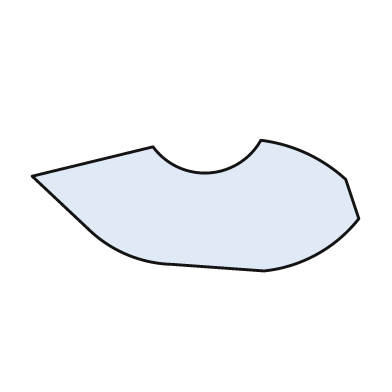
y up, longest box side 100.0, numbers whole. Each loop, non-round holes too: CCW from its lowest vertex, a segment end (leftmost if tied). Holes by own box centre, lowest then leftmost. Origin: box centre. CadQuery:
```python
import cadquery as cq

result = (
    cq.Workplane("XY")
    .moveTo(21.0, -20.0)
    .threePointArc((37.0, -15.0), (50.0, -4.0))
    .lineTo(46.0, 8.0)
    .threePointArc((34.0, 16.0), (20.0, 20.0))
    .threePointArc((4.0, 10.0), (-13.0, 18.0))
    .lineTo(-50.0, 9.0)
    .lineTo(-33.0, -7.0)
    .threePointArc((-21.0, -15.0), (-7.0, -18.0))
    .close()
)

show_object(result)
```